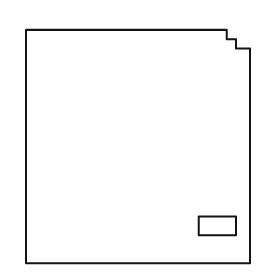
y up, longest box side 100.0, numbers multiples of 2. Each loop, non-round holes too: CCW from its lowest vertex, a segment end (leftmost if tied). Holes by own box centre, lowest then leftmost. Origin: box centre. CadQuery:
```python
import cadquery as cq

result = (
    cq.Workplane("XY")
    .moveTo(-48.0, -50.0)
    .lineTo(48.0, -50.0)
    .lineTo(48.0, 42.0)
    .lineTo(42.0, 42.0)
    .lineTo(42.0, 46.0)
    .lineTo(38.0, 46.0)
    .lineTo(38.0, 50.0)
    .lineTo(-48.0, 50.0)
    .close()
    .moveTo(26.0, -38.0)
    .lineTo(42.0, -38.0)
    .lineTo(42.0, -30.0)
    .lineTo(26.0, -30.0)
    .close()
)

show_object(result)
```